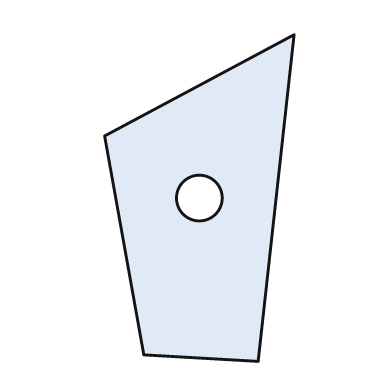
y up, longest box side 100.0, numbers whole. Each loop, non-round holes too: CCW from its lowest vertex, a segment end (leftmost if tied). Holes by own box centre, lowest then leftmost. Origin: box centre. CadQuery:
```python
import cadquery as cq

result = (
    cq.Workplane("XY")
    .moveTo(18.0, -50.0)
    .lineTo(29.0, 50.0)
    .lineTo(-29.0, 19.0)
    .lineTo(-17.0, -48.0)
    .close()
    .moveTo(0.0, 0.0)
    .circle(7.0)
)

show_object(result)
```